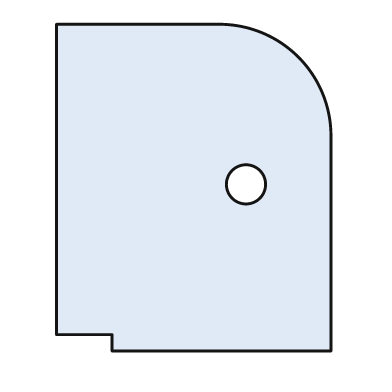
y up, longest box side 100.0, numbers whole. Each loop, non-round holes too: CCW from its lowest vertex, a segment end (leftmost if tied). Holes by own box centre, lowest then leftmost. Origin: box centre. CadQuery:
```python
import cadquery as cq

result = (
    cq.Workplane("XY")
    .moveTo(-25.0, -50.0)
    .lineTo(42.0, -50.0)
    .lineTo(42.0, 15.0)
    .threePointArc((32.0, 40.0), (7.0, 50.0))
    .lineTo(-42.0, 50.0)
    .lineTo(-42.0, -45.0)
    .lineTo(-25.0, -45.0)
    .close()
    .moveTo(16.0, 1.0)
    .circle(6.0)
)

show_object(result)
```